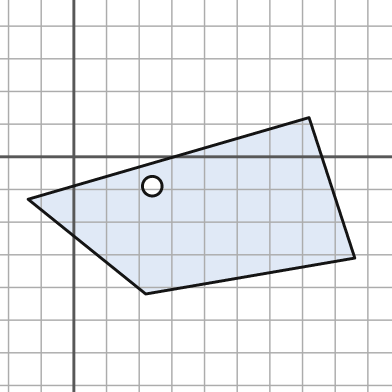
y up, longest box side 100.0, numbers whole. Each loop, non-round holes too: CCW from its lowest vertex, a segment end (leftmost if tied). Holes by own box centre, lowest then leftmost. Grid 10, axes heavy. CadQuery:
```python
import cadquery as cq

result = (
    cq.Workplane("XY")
    .moveTo(22.0, -42.0)
    .lineTo(86.0, -31.0)
    .lineTo(72.0, 12.0)
    .lineTo(-14.0, -13.0)
    .close()
    .moveTo(24.0, -9.0)
    .circle(3.0)
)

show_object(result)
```